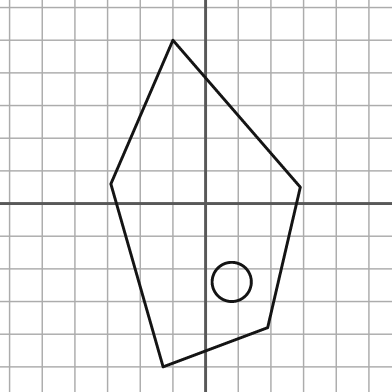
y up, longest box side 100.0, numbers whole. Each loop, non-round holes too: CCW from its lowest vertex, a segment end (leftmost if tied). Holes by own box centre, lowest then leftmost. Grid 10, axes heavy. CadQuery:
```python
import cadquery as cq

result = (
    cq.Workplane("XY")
    .moveTo(-13.0, -50.0)
    .lineTo(19.0, -38.0)
    .lineTo(29.0, 5.0)
    .lineTo(-10.0, 50.0)
    .lineTo(-29.0, 6.0)
    .close()
    .moveTo(8.0, -24.0)
    .circle(6.0)
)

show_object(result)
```